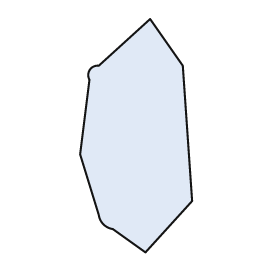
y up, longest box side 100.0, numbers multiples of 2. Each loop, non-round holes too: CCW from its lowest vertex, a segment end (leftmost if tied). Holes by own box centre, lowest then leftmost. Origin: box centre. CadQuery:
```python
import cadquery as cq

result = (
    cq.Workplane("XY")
    .moveTo(4.0, -50.0)
    .lineTo(24.0, -28.0)
    .lineTo(20.0, 30.0)
    .lineTo(6.0, 50.0)
    .lineTo(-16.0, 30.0)
    .threePointArc((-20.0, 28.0), (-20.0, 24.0))
    .lineTo(-24.0, -8.0)
    .lineTo(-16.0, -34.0)
    .threePointArc((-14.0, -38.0), (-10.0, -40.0))
    .close()
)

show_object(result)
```